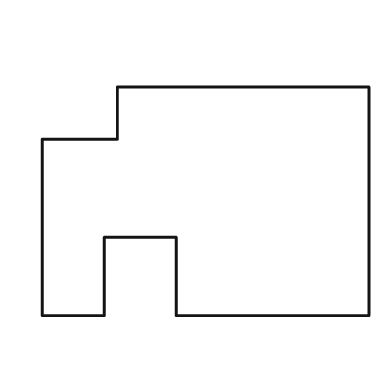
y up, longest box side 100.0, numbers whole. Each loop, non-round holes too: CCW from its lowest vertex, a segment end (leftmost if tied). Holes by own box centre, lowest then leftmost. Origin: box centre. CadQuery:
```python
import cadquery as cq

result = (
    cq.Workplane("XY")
    .moveTo(-50.0, -35.0)
    .lineTo(-31.0, -35.0)
    .lineTo(-31.0, -11.0)
    .lineTo(-9.0, -11.0)
    .lineTo(-9.0, -35.0)
    .lineTo(50.0, -35.0)
    .lineTo(50.0, 35.0)
    .lineTo(-27.0, 35.0)
    .lineTo(-27.0, 19.0)
    .lineTo(-50.0, 19.0)
    .close()
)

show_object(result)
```